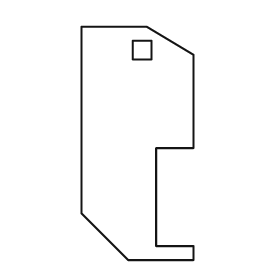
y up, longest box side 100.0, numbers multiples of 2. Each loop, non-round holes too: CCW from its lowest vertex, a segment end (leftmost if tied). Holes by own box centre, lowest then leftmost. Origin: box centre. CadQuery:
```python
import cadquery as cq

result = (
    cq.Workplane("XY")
    .moveTo(-4.0, -50.0)
    .lineTo(24.0, -50.0)
    .lineTo(24.0, -44.0)
    .lineTo(8.0, -44.0)
    .lineTo(8.0, -2.0)
    .lineTo(24.0, -2.0)
    .lineTo(24.0, 38.0)
    .lineTo(4.0, 50.0)
    .lineTo(-24.0, 50.0)
    .lineTo(-24.0, -30.0)
    .close()
    .moveTo(-2.0, 36.0)
    .lineTo(6.0, 36.0)
    .lineTo(6.0, 44.0)
    .lineTo(-2.0, 44.0)
    .close()
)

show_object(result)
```